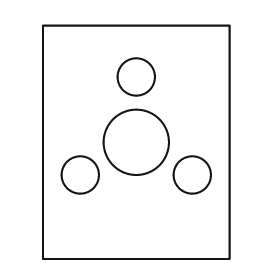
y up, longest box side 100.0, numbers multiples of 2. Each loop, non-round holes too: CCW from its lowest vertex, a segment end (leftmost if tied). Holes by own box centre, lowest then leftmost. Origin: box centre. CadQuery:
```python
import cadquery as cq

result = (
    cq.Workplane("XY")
    .moveTo(-40.0, -50.0)
    .lineTo(40.0, -50.0)
    .lineTo(40.0, 50.0)
    .lineTo(-40.0, 50.0)
    .close()
    .moveTo(-24.0, -14.0)
    .circle(8.0)
    .moveTo(24.0, -14.0)
    .circle(8.0)
    .moveTo(0.0, 0.0)
    .circle(14.0)
    .moveTo(0.0, 28.0)
    .circle(8.0)
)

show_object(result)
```